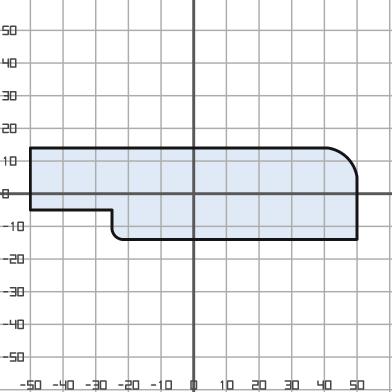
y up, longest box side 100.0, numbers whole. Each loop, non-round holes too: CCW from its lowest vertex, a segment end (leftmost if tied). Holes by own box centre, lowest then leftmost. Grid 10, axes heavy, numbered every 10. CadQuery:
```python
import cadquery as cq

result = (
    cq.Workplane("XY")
    .moveTo(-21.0, -14.0)
    .lineTo(50.0, -14.0)
    .lineTo(50.0, 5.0)
    .threePointArc((47.0, 11.0), (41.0, 14.0))
    .lineTo(-50.0, 14.0)
    .lineTo(-50.0, -5.0)
    .lineTo(-25.0, -5.0)
    .lineTo(-25.0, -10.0)
    .threePointArc((-24.0, -13.0), (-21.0, -14.0))
    .close()
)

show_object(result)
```